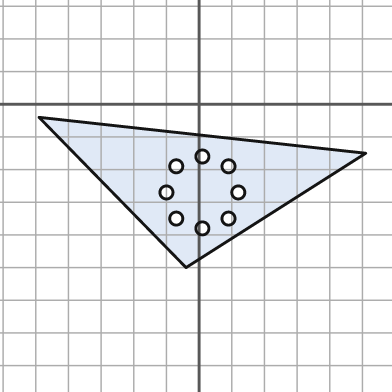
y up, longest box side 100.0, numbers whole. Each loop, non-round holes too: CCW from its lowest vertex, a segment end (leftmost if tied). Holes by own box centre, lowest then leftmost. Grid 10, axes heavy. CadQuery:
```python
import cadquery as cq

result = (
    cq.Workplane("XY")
    .moveTo(-4.0, -50.0)
    .lineTo(51.0, -15.0)
    .lineTo(-49.0, -4.0)
    .close()
    .moveTo(1.0, -38.0)
    .circle(2.0)
    .moveTo(-7.0, -35.0)
    .circle(2.0)
    .moveTo(9.0, -35.0)
    .circle(2.0)
    .moveTo(-10.0, -27.0)
    .circle(2.0)
    .moveTo(12.0, -27.0)
    .circle(2.0)
    .moveTo(-7.0, -19.0)
    .circle(2.0)
    .moveTo(9.0, -19.0)
    .circle(2.0)
    .moveTo(1.0, -16.0)
    .circle(2.0)
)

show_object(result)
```